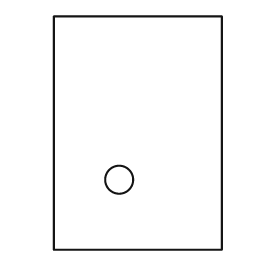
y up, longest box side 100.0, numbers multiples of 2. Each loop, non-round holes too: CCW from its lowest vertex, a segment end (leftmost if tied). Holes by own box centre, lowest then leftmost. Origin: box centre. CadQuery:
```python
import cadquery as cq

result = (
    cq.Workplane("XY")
    .moveTo(-36.0, -50.0)
    .lineTo(36.0, -50.0)
    .lineTo(36.0, 50.0)
    .lineTo(-36.0, 50.0)
    .close()
    .moveTo(-8.0, -20.0)
    .circle(6.0)
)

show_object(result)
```